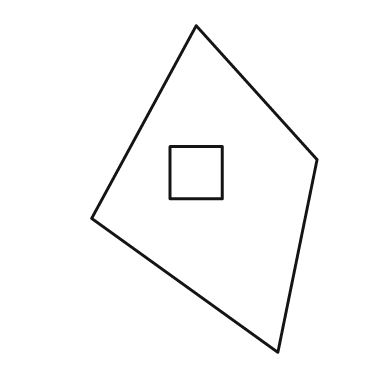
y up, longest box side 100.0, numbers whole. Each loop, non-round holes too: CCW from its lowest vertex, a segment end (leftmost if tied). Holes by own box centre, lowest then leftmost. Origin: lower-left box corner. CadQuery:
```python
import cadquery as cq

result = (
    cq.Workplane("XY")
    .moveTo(57.0, 0.0)
    .lineTo(69.0, 59.0)
    .lineTo(32.0, 100.0)
    .lineTo(0.0, 41.0)
    .close()
    .moveTo(24.0, 47.0)
    .lineTo(40.0, 47.0)
    .lineTo(40.0, 63.0)
    .lineTo(24.0, 63.0)
    .close()
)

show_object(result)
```